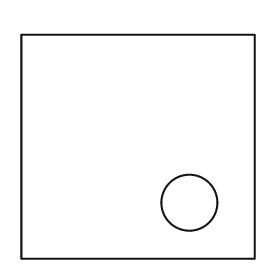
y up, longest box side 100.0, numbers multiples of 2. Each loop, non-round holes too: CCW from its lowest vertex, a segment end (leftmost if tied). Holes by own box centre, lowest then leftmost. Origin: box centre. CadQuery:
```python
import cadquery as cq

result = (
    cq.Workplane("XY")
    .moveTo(-50.0, -48.0)
    .lineTo(50.0, -48.0)
    .lineTo(50.0, 48.0)
    .lineTo(-50.0, 48.0)
    .close()
    .moveTo(22.0, -24.0)
    .circle(12.0)
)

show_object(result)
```